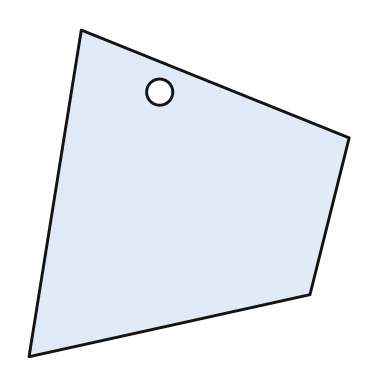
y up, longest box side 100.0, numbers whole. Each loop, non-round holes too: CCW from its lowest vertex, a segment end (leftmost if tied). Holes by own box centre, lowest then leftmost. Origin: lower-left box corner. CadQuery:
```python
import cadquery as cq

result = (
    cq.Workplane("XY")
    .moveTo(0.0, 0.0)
    .lineTo(86.0, 19.0)
    .lineTo(98.0, 67.0)
    .lineTo(16.0, 100.0)
    .close()
    .moveTo(40.0, 81.0)
    .circle(4.0)
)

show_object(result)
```